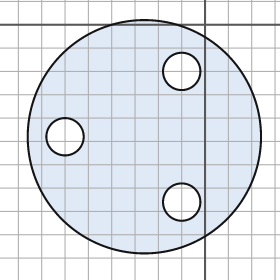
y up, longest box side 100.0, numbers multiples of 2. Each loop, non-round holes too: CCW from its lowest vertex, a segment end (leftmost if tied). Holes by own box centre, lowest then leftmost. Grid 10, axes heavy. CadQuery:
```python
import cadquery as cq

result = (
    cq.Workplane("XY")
    .moveTo(-26.0, -48.0)
    .circle(50.0)
    .moveTo(-10.0, -76.0)
    .circle(8.0)
    .moveTo(-60.0, -48.0)
    .circle(8.0)
    .moveTo(-10.0, -20.0)
    .circle(8.0)
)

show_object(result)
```